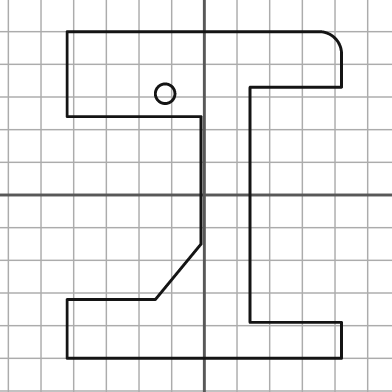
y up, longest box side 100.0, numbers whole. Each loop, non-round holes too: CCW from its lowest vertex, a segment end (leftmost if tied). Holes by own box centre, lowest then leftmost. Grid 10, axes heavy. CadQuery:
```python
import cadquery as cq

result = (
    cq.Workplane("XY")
    .moveTo(-42.0, -50.0)
    .lineTo(42.0, -50.0)
    .lineTo(42.0, -39.0)
    .lineTo(14.0, -39.0)
    .lineTo(14.0, 33.0)
    .lineTo(42.0, 33.0)
    .lineTo(42.0, 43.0)
    .threePointArc((40.0, 48.0), (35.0, 50.0))
    .lineTo(-42.0, 50.0)
    .lineTo(-42.0, 24.0)
    .lineTo(-1.0, 24.0)
    .lineTo(-1.0, -15.0)
    .lineTo(-15.0, -32.0)
    .lineTo(-42.0, -32.0)
    .close()
    .moveTo(-12.0, 31.0)
    .circle(3.0)
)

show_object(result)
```